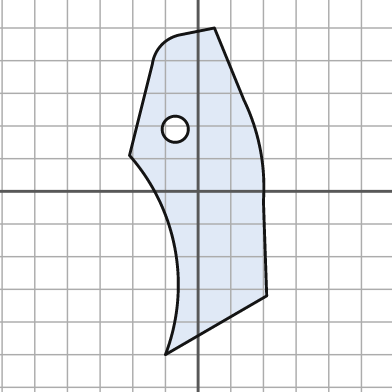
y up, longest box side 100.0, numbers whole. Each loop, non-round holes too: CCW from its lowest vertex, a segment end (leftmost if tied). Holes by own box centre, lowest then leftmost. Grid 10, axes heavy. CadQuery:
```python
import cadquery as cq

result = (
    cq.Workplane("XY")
    .moveTo(-10.0, -50.0)
    .lineTo(21.0, -32.0)
    .lineTo(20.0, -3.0)
    .threePointArc((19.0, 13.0), (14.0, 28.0))
    .lineTo(5.0, 50.0)
    .lineTo(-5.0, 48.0)
    .threePointArc((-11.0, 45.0), (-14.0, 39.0))
    .lineTo(-21.0, 11.0)
    .threePointArc((-7.0, -18.0), (-10.0, -50.0))
    .close()
    .moveTo(-7.0, 19.0)
    .circle(4.0)
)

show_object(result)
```